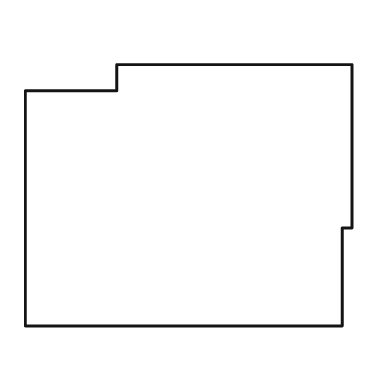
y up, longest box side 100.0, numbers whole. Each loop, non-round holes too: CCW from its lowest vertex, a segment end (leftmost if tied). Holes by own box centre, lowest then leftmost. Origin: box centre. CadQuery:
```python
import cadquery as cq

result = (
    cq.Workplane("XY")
    .moveTo(-50.0, -40.0)
    .lineTo(47.0, -40.0)
    .lineTo(47.0, -10.0)
    .lineTo(50.0, -10.0)
    .lineTo(50.0, 40.0)
    .lineTo(-22.0, 40.0)
    .lineTo(-22.0, 32.0)
    .lineTo(-50.0, 32.0)
    .close()
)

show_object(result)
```